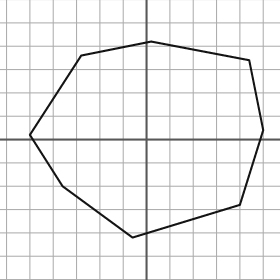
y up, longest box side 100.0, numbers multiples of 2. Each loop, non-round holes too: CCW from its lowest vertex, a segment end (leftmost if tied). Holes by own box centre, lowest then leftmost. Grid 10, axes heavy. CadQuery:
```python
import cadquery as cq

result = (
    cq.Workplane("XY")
    .moveTo(-6.0, -42.0)
    .lineTo(40.0, -28.0)
    .lineTo(50.0, 4.0)
    .lineTo(44.0, 34.0)
    .lineTo(2.0, 42.0)
    .lineTo(-28.0, 36.0)
    .lineTo(-50.0, 2.0)
    .lineTo(-36.0, -20.0)
    .close()
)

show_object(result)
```